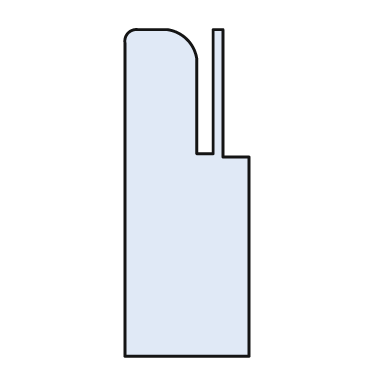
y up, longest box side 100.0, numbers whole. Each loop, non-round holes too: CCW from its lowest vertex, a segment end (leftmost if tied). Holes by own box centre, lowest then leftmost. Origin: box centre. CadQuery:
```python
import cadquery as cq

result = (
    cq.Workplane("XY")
    .moveTo(-19.0, -50.0)
    .lineTo(19.0, -50.0)
    .lineTo(19.0, 11.0)
    .lineTo(11.0, 11.0)
    .lineTo(11.0, 50.0)
    .lineTo(8.0, 50.0)
    .lineTo(8.0, 12.0)
    .lineTo(3.0, 12.0)
    .lineTo(3.0, 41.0)
    .threePointArc((0.0, 47.0), (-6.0, 50.0))
    .lineTo(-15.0, 50.0)
    .threePointArc((-18.0, 49.0), (-19.0, 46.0))
    .close()
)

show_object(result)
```